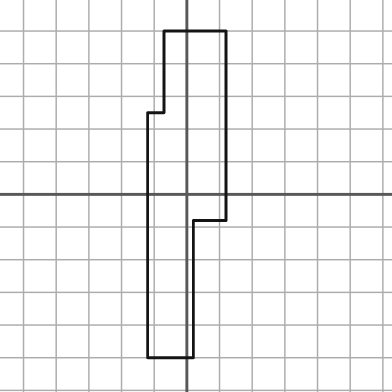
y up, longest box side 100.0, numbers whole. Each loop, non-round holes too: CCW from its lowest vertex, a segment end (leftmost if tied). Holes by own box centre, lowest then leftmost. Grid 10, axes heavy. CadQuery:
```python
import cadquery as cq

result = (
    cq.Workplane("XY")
    .moveTo(-12.0, -50.0)
    .lineTo(2.0, -50.0)
    .lineTo(2.0, -8.0)
    .lineTo(12.0, -8.0)
    .lineTo(12.0, 50.0)
    .lineTo(-7.0, 50.0)
    .lineTo(-7.0, 25.0)
    .lineTo(-12.0, 25.0)
    .close()
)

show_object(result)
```